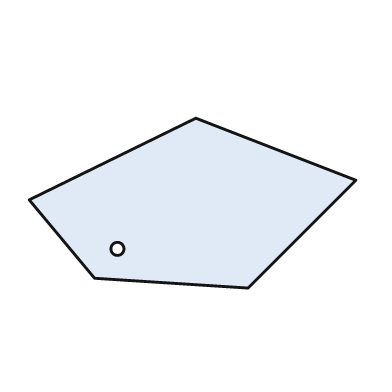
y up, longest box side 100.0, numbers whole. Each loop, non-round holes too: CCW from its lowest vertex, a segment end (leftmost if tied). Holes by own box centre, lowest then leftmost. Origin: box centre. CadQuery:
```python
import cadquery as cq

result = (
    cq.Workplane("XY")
    .moveTo(17.0, -26.0)
    .lineTo(50.0, 7.0)
    .lineTo(1.0, 26.0)
    .lineTo(-50.0, 1.0)
    .lineTo(-30.0, -23.0)
    .close()
    .moveTo(-23.0, -14.0)
    .circle(2.0)
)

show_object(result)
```